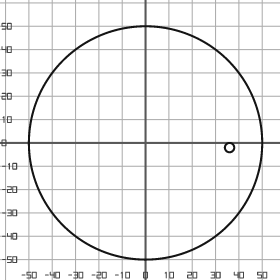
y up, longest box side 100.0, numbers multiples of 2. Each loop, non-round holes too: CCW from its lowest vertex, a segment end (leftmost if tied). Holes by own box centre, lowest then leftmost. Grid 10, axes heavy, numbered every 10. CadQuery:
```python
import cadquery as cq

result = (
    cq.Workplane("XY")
    .moveTo(0.0, 0.0)
    .circle(50.0)
    .moveTo(36.0, -2.0)
    .circle(2.0)
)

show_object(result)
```